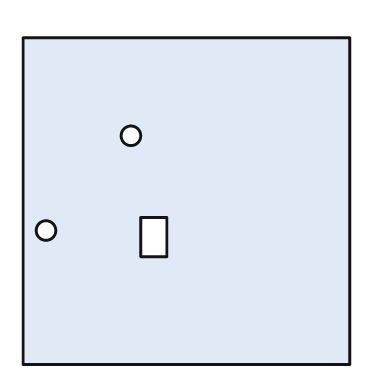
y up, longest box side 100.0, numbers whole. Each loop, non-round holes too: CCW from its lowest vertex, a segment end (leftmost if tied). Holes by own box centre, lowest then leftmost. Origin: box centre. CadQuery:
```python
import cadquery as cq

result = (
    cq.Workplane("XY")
    .moveTo(-50.0, -50.0)
    .lineTo(50.0, -50.0)
    .lineTo(50.0, 50.0)
    .lineTo(-50.0, 50.0)
    .close()
    .moveTo(-14.0, -17.0)
    .lineTo(-6.0, -17.0)
    .lineTo(-6.0, -5.0)
    .lineTo(-14.0, -5.0)
    .close()
    .moveTo(-43.0, -9.0)
    .circle(3.0)
    .moveTo(-17.0, 20.0)
    .circle(3.0)
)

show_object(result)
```